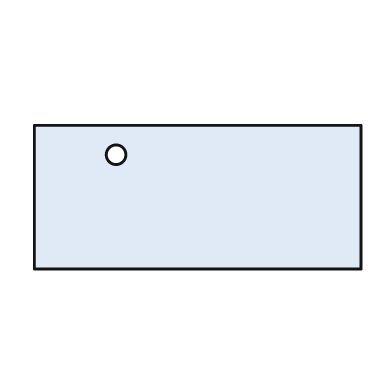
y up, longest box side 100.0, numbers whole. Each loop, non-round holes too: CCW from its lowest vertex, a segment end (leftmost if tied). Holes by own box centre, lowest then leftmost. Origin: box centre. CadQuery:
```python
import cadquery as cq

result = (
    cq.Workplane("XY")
    .moveTo(-50.0, -22.0)
    .lineTo(50.0, -22.0)
    .lineTo(50.0, 22.0)
    .lineTo(-50.0, 22.0)
    .close()
    .moveTo(-25.0, 13.0)
    .circle(3.0)
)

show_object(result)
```